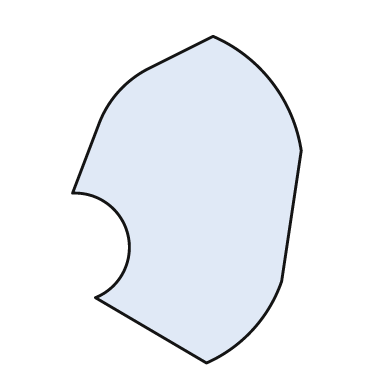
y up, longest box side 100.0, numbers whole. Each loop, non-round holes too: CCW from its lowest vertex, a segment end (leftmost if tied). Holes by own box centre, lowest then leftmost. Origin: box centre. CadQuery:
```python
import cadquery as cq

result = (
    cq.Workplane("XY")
    .moveTo(6.0, -50.0)
    .threePointArc((20.0, -40.0), (29.0, -25.0))
    .lineTo(35.0, 15.0)
    .threePointArc((26.0, 36.0), (8.0, 50.0))
    .lineTo(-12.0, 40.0)
    .threePointArc((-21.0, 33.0), (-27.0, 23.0))
    .lineTo(-35.0, 2.0)
    .threePointArc((-18.0, -11.0), (-28.0, -30.0))
    .close()
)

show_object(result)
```